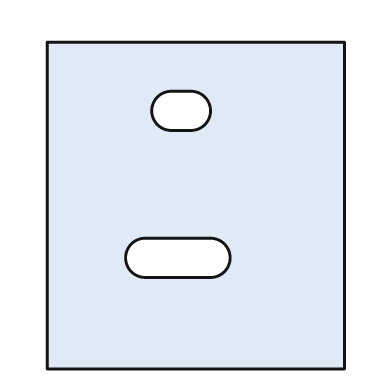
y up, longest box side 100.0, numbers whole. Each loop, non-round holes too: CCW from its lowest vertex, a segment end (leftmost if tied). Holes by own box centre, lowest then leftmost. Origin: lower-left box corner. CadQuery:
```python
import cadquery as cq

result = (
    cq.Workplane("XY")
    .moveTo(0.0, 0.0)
    .lineTo(91.0, 0.0)
    .lineTo(91.0, 100.0)
    .lineTo(0.0, 100.0)
    .close()
    .moveTo(30.0, 28.0)
    .lineTo(50.0, 28.0)
    .threePointArc((56.0, 34.0), (50.0, 40.0))
    .lineTo(30.0, 40.0)
    .threePointArc((24.0, 34.0), (30.0, 28.0))
    .close()
    .moveTo(38.0, 73.0)
    .lineTo(44.0, 73.0)
    .threePointArc((50.0, 79.0), (44.0, 85.0))
    .lineTo(38.0, 85.0)
    .threePointArc((32.0, 79.0), (38.0, 73.0))
    .close()
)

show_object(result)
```